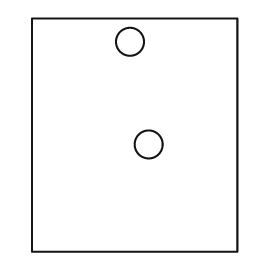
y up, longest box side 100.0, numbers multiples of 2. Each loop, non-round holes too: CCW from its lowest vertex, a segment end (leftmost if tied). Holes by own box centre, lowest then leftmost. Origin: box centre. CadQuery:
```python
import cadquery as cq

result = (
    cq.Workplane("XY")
    .moveTo(-44.0, -50.0)
    .lineTo(44.0, -50.0)
    .lineTo(44.0, 50.0)
    .lineTo(-44.0, 50.0)
    .close()
    .moveTo(6.0, -4.0)
    .circle(6.0)
    .moveTo(-2.0, 40.0)
    .circle(6.0)
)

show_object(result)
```